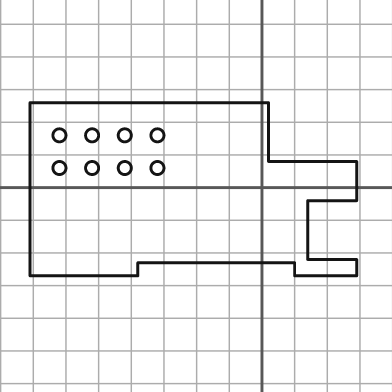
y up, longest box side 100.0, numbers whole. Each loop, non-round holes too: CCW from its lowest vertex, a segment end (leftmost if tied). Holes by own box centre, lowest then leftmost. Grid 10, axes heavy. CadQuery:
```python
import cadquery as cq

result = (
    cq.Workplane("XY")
    .moveTo(-71.0, -27.0)
    .lineTo(-38.0, -27.0)
    .lineTo(-38.0, -23.0)
    .lineTo(10.0, -23.0)
    .lineTo(10.0, -27.0)
    .lineTo(29.0, -27.0)
    .lineTo(29.0, -22.0)
    .lineTo(14.0, -22.0)
    .lineTo(14.0, -4.0)
    .lineTo(29.0, -4.0)
    .lineTo(29.0, 8.0)
    .lineTo(2.0, 8.0)
    .lineTo(2.0, 26.0)
    .lineTo(-71.0, 26.0)
    .close()
    .moveTo(-62.0, 6.0)
    .circle(2.0)
    .moveTo(-52.0, 6.0)
    .circle(2.0)
    .moveTo(-42.0, 6.0)
    .circle(2.0)
    .moveTo(-32.0, 6.0)
    .circle(2.0)
    .moveTo(-62.0, 16.0)
    .circle(2.0)
    .moveTo(-52.0, 16.0)
    .circle(2.0)
    .moveTo(-42.0, 16.0)
    .circle(2.0)
    .moveTo(-32.0, 16.0)
    .circle(2.0)
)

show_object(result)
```